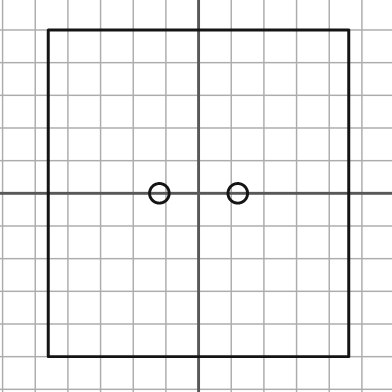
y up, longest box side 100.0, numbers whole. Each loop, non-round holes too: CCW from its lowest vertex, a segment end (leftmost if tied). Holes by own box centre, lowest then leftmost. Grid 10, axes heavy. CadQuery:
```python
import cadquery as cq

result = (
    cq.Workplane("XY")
    .moveTo(-46.0, -50.0)
    .lineTo(46.0, -50.0)
    .lineTo(46.0, 50.0)
    .lineTo(-46.0, 50.0)
    .close()
    .moveTo(-12.0, 0.0)
    .circle(3.0)
    .moveTo(12.0, 0.0)
    .circle(3.0)
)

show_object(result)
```